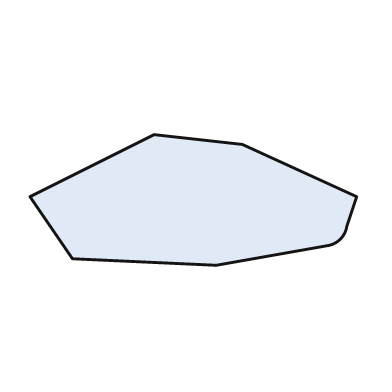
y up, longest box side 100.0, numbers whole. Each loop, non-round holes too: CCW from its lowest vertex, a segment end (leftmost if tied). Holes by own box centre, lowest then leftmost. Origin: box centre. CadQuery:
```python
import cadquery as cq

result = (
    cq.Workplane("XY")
    .moveTo(7.0, -20.0)
    .lineTo(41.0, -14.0)
    .threePointArc((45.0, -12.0), (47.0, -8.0))
    .lineTo(50.0, 1.0)
    .lineTo(15.0, 17.0)
    .lineTo(-12.0, 20.0)
    .lineTo(-50.0, 1.0)
    .lineTo(-37.0, -18.0)
    .close()
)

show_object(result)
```